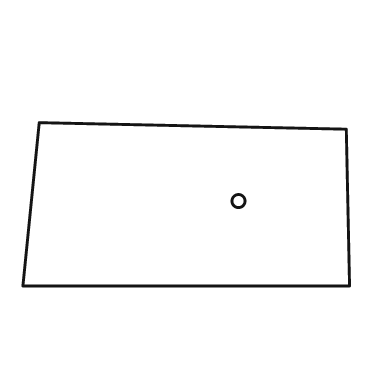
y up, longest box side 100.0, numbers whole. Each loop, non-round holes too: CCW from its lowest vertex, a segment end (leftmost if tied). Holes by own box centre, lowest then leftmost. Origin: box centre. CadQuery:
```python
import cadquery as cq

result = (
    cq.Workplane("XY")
    .moveTo(-50.0, -25.0)
    .lineTo(50.0, -25.0)
    .lineTo(49.0, 23.0)
    .lineTo(-45.0, 25.0)
    .close()
    .moveTo(16.0, 1.0)
    .circle(2.0)
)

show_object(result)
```